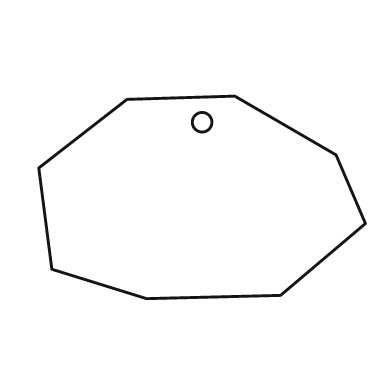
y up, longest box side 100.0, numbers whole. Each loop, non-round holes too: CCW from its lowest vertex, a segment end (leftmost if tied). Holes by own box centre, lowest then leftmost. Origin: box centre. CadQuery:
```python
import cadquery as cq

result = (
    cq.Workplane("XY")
    .moveTo(-17.0, -31.0)
    .lineTo(24.0, -30.0)
    .lineTo(50.0, -8.0)
    .lineTo(41.0, 13.0)
    .lineTo(10.0, 31.0)
    .lineTo(-23.0, 30.0)
    .lineTo(-50.0, 9.0)
    .lineTo(-46.0, -22.0)
    .close()
    .moveTo(0.0, 23.0)
    .circle(3.0)
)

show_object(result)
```